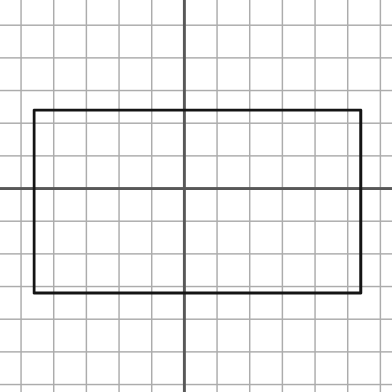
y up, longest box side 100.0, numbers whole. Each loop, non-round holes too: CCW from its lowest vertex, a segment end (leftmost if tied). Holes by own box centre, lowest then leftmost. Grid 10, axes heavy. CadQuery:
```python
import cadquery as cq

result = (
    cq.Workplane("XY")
    .moveTo(-46.0, -32.0)
    .lineTo(54.0, -32.0)
    .lineTo(54.0, 24.0)
    .lineTo(-46.0, 24.0)
    .close()
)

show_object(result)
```